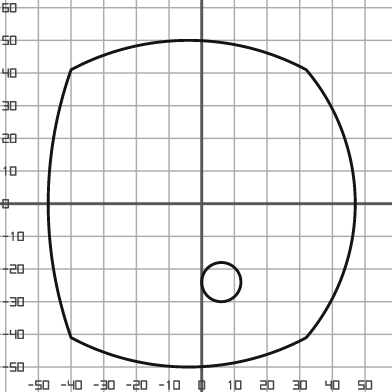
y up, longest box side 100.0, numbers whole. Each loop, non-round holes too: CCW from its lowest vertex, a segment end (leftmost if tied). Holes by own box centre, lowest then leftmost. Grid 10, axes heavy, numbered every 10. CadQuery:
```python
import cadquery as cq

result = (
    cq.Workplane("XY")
    .moveTo(-40.0, -41.0)
    .threePointArc((-4.0, -50.0), (32.0, -41.0))
    .threePointArc((47.0, 0.0), (32.0, 41.0))
    .threePointArc((-4.0, 50.0), (-40.0, 41.0))
    .threePointArc((-47.0, 0.0), (-40.0, -41.0))
    .close()
    .moveTo(6.0, -24.0)
    .circle(6.0)
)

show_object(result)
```